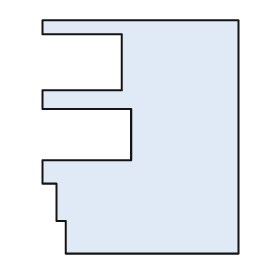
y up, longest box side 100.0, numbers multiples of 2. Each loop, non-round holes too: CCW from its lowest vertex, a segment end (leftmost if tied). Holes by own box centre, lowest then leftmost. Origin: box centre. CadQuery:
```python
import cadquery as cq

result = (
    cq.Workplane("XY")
    .moveTo(-32.0, -50.0)
    .lineTo(42.0, -50.0)
    .lineTo(42.0, 50.0)
    .lineTo(-42.0, 50.0)
    .lineTo(-42.0, 44.0)
    .lineTo(-8.0, 44.0)
    .lineTo(-8.0, 20.0)
    .lineTo(-42.0, 20.0)
    .lineTo(-42.0, 12.0)
    .lineTo(-4.0, 12.0)
    .lineTo(-4.0, -10.0)
    .lineTo(-42.0, -10.0)
    .lineTo(-42.0, -20.0)
    .lineTo(-36.0, -20.0)
    .lineTo(-36.0, -36.0)
    .lineTo(-32.0, -36.0)
    .close()
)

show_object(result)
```